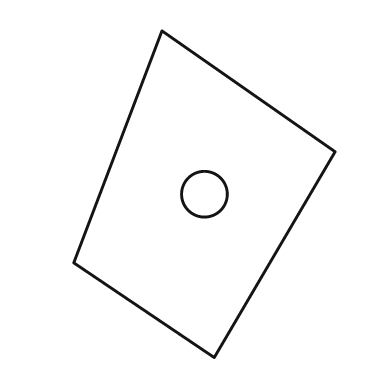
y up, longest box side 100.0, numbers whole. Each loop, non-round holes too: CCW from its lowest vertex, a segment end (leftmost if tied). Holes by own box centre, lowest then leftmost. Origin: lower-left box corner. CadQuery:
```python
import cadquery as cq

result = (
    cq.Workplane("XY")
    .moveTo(43.0, 0.0)
    .lineTo(80.0, 63.0)
    .lineTo(27.0, 100.0)
    .lineTo(0.0, 29.0)
    .close()
    .moveTo(40.0, 50.0)
    .circle(7.0)
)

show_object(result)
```